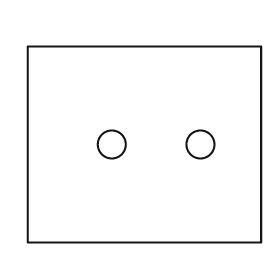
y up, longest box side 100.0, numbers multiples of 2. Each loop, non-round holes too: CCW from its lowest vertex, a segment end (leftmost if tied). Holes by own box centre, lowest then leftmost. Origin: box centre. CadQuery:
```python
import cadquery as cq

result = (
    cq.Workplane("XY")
    .moveTo(-50.0, -42.0)
    .lineTo(50.0, -42.0)
    .lineTo(50.0, 42.0)
    .lineTo(-50.0, 42.0)
    .close()
    .moveTo(-14.0, 0.0)
    .circle(6.0)
    .moveTo(24.0, 0.0)
    .circle(6.0)
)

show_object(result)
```